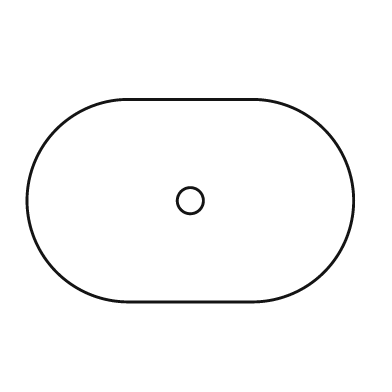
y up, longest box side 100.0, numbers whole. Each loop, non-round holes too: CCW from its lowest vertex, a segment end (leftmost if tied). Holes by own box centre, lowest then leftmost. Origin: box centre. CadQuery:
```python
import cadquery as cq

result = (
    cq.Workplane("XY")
    .moveTo(-19.0, -31.0)
    .lineTo(19.0, -31.0)
    .threePointArc((50.0, 0.0), (19.0, 31.0))
    .lineTo(-19.0, 31.0)
    .threePointArc((-50.0, 0.0), (-19.0, -31.0))
    .close()
    .moveTo(0.0, 0.0)
    .circle(4.0)
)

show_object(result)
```